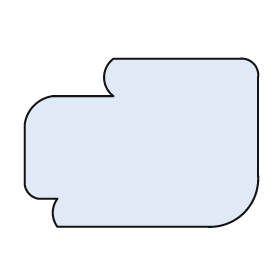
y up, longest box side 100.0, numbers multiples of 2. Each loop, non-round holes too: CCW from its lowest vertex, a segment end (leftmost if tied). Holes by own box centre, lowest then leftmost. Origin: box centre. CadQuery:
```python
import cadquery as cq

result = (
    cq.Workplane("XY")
    .moveTo(-36.0, -36.0)
    .lineTo(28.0, -36.0)
    .threePointArc((44.0, -30.0), (50.0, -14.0))
    .lineTo(50.0, 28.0)
    .threePointArc((48.0, 34.0), (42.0, 36.0))
    .lineTo(-12.0, 36.0)
    .threePointArc((-16.0, 28.0), (-12.0, 20.0))
    .lineTo(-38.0, 20.0)
    .threePointArc((-46.0, 16.0), (-50.0, 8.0))
    .lineTo(-50.0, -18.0)
    .threePointArc((-48.0, -22.0), (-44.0, -24.0))
    .lineTo(-36.0, -24.0)
    .threePointArc((-38.0, -30.0), (-36.0, -36.0))
    .close()
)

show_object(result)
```